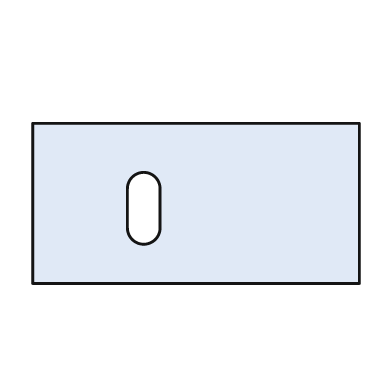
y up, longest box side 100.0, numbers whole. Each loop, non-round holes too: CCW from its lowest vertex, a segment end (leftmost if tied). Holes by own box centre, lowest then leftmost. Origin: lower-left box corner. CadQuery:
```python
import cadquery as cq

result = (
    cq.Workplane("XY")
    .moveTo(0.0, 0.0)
    .lineTo(100.0, 0.0)
    .lineTo(100.0, 49.0)
    .lineTo(0.0, 49.0)
    .close()
    .moveTo(29.0, 17.0)
    .threePointArc((34.0, 12.0), (39.0, 17.0))
    .lineTo(39.0, 29.0)
    .threePointArc((34.0, 34.0), (29.0, 29.0))
    .close()
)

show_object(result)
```